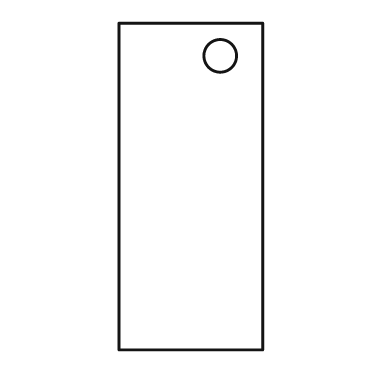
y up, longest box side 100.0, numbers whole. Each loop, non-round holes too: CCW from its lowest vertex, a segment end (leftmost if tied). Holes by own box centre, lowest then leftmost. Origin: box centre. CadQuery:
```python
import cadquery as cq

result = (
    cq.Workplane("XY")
    .moveTo(-22.0, -50.0)
    .lineTo(22.0, -50.0)
    .lineTo(22.0, 50.0)
    .lineTo(-22.0, 50.0)
    .close()
    .moveTo(9.0, 40.0)
    .circle(5.0)
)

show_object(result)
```